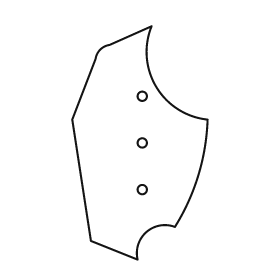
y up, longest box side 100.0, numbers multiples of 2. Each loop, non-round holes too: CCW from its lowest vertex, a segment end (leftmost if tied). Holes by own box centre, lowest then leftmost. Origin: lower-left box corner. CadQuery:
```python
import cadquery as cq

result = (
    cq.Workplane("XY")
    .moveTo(28.0, 0.0)
    .threePointArc((32.0, 12.0), (44.0, 14.0))
    .threePointArc((54.0, 36.0), (58.0, 60.0))
    .threePointArc((36.0, 74.0), (34.0, 100.0))
    .lineTo(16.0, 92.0)
    .threePointArc((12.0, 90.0), (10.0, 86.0))
    .lineTo(0.0, 60.0)
    .lineTo(8.0, 8.0)
    .close()
    .moveTo(30.0, 30.0)
    .circle(2.0)
    .moveTo(30.0, 50.0)
    .circle(2.0)
    .moveTo(30.0, 70.0)
    .circle(2.0)
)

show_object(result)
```